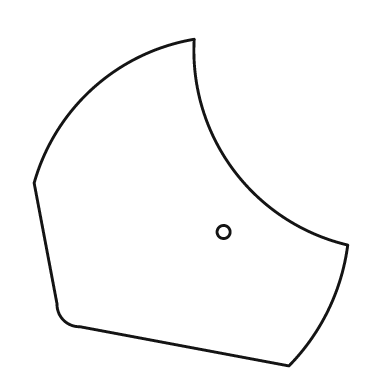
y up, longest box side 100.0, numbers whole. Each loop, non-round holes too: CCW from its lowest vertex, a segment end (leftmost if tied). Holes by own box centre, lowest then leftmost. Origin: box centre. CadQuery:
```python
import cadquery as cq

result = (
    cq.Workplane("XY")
    .moveTo(30.0, -50.0)
    .threePointArc((42.0, -33.0), (48.0, -13.0))
    .threePointArc((13.0, 10.0), (1.0, 50.0))
    .threePointArc((-30.0, 35.0), (-48.0, 6.0))
    .lineTo(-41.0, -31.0)
    .threePointArc((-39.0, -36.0), (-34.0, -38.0))
    .close()
    .moveTo(10.0, -9.0)
    .circle(2.0)
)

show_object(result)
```